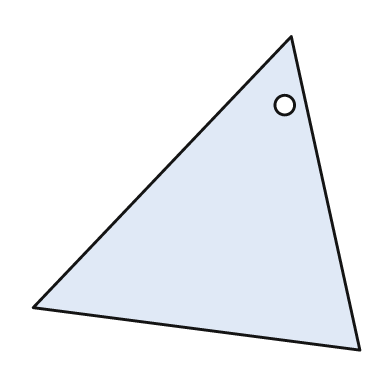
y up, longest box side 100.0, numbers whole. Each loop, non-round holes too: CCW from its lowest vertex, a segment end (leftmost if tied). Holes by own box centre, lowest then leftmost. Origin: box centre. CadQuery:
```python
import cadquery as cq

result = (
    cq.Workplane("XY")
    .moveTo(50.0, -48.0)
    .lineTo(29.0, 48.0)
    .lineTo(-50.0, -35.0)
    .close()
    .moveTo(27.0, 27.0)
    .circle(3.0)
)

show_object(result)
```